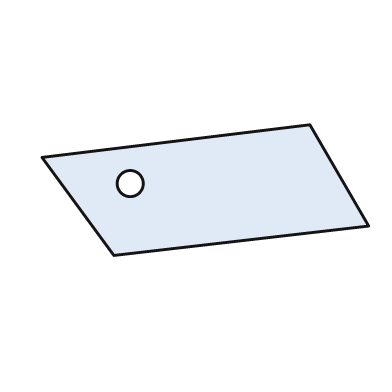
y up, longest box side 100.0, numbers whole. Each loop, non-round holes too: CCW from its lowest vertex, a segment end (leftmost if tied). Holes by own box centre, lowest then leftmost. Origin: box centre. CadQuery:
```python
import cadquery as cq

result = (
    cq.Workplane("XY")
    .moveTo(-28.0, -20.0)
    .lineTo(50.0, -11.0)
    .lineTo(32.0, 20.0)
    .lineTo(-50.0, 10.0)
    .close()
    .moveTo(-23.0, 2.0)
    .circle(4.0)
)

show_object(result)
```